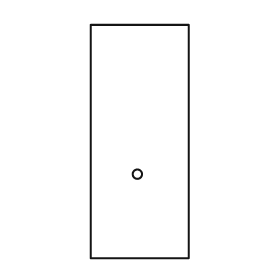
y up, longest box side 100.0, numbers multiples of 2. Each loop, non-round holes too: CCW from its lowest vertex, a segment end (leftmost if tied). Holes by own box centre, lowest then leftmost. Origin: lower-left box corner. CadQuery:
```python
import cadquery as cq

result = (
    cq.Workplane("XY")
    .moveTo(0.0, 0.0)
    .lineTo(42.0, 0.0)
    .lineTo(42.0, 100.0)
    .lineTo(0.0, 100.0)
    .close()
    .moveTo(20.0, 36.0)
    .circle(2.0)
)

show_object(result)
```